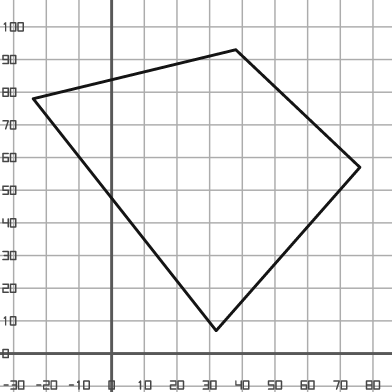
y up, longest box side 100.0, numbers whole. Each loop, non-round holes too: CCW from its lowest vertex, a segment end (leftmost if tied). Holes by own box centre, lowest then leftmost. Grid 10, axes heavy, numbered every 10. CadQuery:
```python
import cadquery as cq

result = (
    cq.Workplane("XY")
    .moveTo(32.0, 7.0)
    .lineTo(76.0, 57.0)
    .lineTo(38.0, 93.0)
    .lineTo(-24.0, 78.0)
    .close()
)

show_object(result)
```